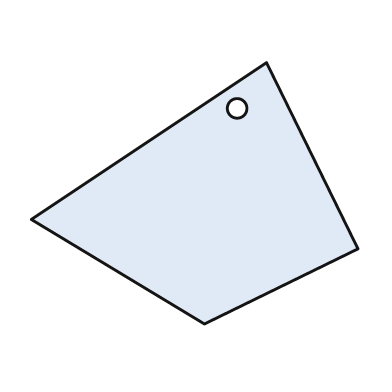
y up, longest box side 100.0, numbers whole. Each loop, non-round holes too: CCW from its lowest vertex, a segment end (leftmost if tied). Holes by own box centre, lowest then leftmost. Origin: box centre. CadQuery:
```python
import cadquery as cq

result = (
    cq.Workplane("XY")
    .moveTo(3.0, -40.0)
    .lineTo(50.0, -17.0)
    .lineTo(22.0, 40.0)
    .lineTo(-50.0, -8.0)
    .close()
    .moveTo(13.0, 26.0)
    .circle(3.0)
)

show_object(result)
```